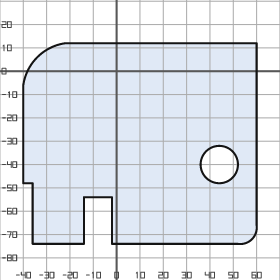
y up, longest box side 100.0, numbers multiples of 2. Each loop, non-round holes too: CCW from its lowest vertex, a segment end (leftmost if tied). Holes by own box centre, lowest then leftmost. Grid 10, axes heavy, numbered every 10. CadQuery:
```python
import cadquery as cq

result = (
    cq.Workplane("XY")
    .moveTo(-36.0, -74.0)
    .lineTo(-14.0, -74.0)
    .lineTo(-14.0, -54.0)
    .lineTo(-2.0, -54.0)
    .lineTo(-2.0, -74.0)
    .lineTo(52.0, -74.0)
    .threePointArc((58.0, -72.0), (60.0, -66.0))
    .lineTo(60.0, 12.0)
    .lineTo(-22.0, 12.0)
    .threePointArc((-34.0, 6.0), (-40.0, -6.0))
    .lineTo(-40.0, -48.0)
    .lineTo(-36.0, -48.0)
    .close()
    .moveTo(44.0, -40.0)
    .circle(8.0)
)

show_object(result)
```